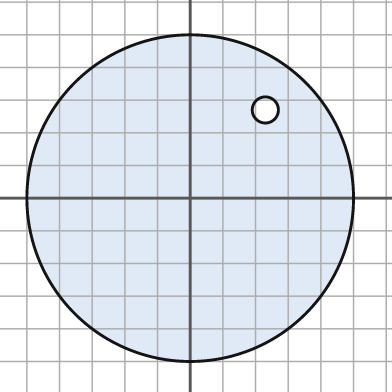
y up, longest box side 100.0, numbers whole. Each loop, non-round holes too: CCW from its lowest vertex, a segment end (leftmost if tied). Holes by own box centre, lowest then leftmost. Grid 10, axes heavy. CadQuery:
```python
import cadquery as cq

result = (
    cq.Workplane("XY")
    .moveTo(0.0, 0.0)
    .circle(50.0)
    .moveTo(23.0, 27.0)
    .circle(4.0)
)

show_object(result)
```